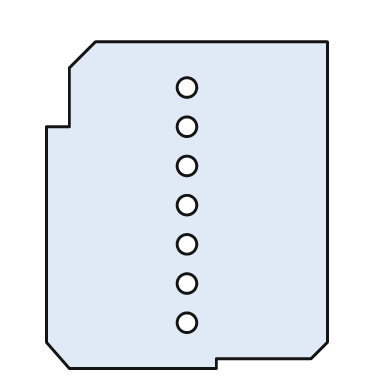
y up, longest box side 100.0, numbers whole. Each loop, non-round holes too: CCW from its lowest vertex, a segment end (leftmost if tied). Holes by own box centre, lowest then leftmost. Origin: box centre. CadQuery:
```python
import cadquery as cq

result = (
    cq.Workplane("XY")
    .moveTo(-36.0, -50.0)
    .lineTo(9.0, -50.0)
    .lineTo(9.0, -47.0)
    .lineTo(38.0, -47.0)
    .lineTo(43.0, -42.0)
    .lineTo(43.0, 50.0)
    .lineTo(-28.0, 50.0)
    .lineTo(-36.0, 42.0)
    .lineTo(-36.0, 24.0)
    .lineTo(-43.0, 24.0)
    .lineTo(-43.0, -42.0)
    .close()
    .moveTo(0.0, -36.0)
    .circle(3.0)
    .moveTo(0.0, -24.0)
    .circle(3.0)
    .moveTo(0.0, -12.0)
    .circle(3.0)
    .moveTo(0.0, 0.0)
    .circle(3.0)
    .moveTo(0.0, 12.0)
    .circle(3.0)
    .moveTo(0.0, 24.0)
    .circle(3.0)
    .moveTo(0.0, 36.0)
    .circle(3.0)
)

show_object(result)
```